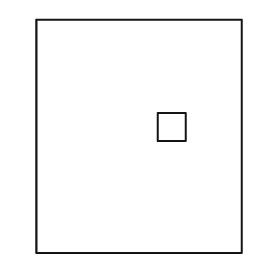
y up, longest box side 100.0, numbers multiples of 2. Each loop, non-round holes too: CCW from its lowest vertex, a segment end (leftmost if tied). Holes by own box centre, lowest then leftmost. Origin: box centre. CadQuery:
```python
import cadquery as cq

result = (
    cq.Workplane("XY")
    .moveTo(-44.0, -50.0)
    .lineTo(44.0, -50.0)
    .lineTo(44.0, 50.0)
    .lineTo(-44.0, 50.0)
    .close()
    .moveTo(8.0, -2.0)
    .lineTo(20.0, -2.0)
    .lineTo(20.0, 10.0)
    .lineTo(8.0, 10.0)
    .close()
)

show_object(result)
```